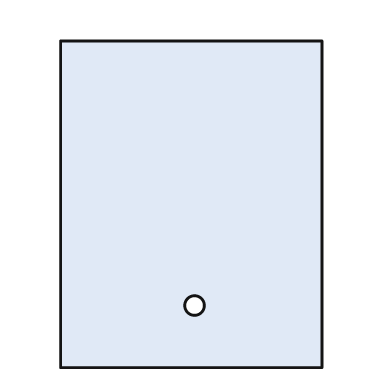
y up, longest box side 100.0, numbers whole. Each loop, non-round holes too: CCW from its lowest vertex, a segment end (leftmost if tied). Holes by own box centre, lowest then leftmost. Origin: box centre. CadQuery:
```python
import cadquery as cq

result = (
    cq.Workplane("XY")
    .moveTo(-40.0, -50.0)
    .lineTo(40.0, -50.0)
    .lineTo(40.0, 50.0)
    .lineTo(-40.0, 50.0)
    .close()
    .moveTo(1.0, -31.0)
    .circle(3.0)
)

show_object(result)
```